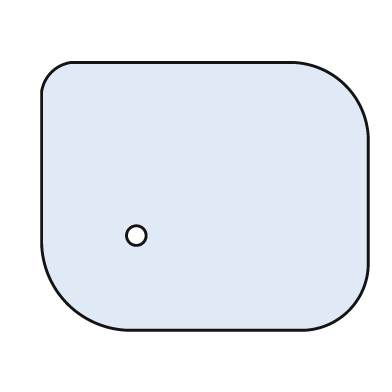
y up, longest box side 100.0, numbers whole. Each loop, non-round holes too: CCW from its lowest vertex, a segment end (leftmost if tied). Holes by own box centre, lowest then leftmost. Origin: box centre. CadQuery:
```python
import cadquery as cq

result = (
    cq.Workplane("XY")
    .moveTo(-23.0, -41.0)
    .lineTo(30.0, -41.0)
    .threePointArc((44.0, -35.0), (50.0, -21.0))
    .lineTo(50.0, 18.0)
    .threePointArc((43.0, 34.0), (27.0, 41.0))
    .lineTo(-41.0, 41.0)
    .threePointArc((-47.0, 38.0), (-50.0, 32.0))
    .lineTo(-50.0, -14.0)
    .threePointArc((-42.0, -33.0), (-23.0, -41.0))
    .close()
    .moveTo(-21.0, -12.0)
    .circle(3.0)
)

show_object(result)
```